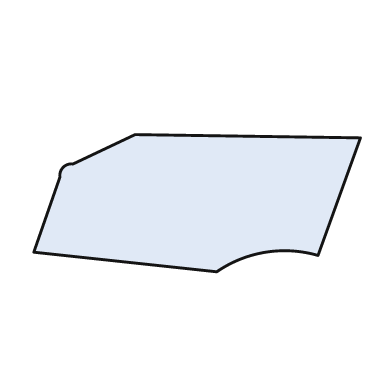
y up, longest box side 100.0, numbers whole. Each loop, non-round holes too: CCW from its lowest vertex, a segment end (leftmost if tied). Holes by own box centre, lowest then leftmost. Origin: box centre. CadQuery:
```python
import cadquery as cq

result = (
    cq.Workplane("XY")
    .moveTo(6.0, -21.0)
    .threePointArc((21.0, -15.0), (37.0, -16.0))
    .lineTo(50.0, 20.0)
    .lineTo(-19.0, 21.0)
    .lineTo(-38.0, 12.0)
    .threePointArc((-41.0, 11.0), (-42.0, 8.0))
    .lineTo(-50.0, -15.0)
    .close()
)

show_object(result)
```